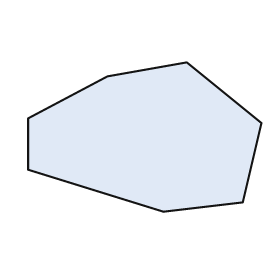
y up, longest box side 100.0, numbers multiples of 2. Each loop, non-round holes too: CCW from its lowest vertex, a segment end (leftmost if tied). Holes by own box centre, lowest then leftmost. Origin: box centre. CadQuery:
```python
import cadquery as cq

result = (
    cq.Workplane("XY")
    .moveTo(8.0, -32.0)
    .lineTo(42.0, -28.0)
    .lineTo(50.0, 6.0)
    .lineTo(18.0, 32.0)
    .lineTo(-16.0, 26.0)
    .lineTo(-50.0, 8.0)
    .lineTo(-50.0, -14.0)
    .close()
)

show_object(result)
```